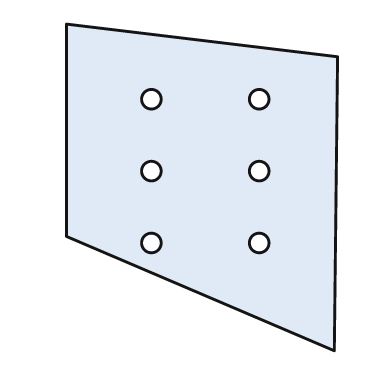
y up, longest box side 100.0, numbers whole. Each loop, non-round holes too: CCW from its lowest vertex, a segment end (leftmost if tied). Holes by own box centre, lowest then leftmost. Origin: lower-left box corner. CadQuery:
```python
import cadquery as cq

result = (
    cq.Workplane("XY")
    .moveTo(82.0, 0.0)
    .lineTo(83.0, 90.0)
    .lineTo(0.0, 100.0)
    .lineTo(0.0, 35.0)
    .close()
    .moveTo(26.0, 33.0)
    .circle(3.0)
    .moveTo(59.0, 33.0)
    .circle(3.0)
    .moveTo(26.0, 55.0)
    .circle(3.0)
    .moveTo(59.0, 55.0)
    .circle(3.0)
    .moveTo(26.0, 77.0)
    .circle(3.0)
    .moveTo(59.0, 77.0)
    .circle(3.0)
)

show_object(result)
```